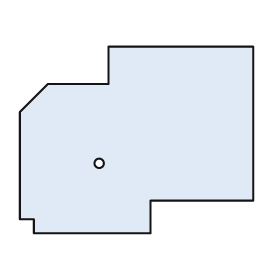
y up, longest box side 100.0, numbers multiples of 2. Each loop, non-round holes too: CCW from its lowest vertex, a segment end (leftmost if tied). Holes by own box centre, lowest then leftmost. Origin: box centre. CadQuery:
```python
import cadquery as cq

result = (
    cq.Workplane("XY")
    .moveTo(-44.0, -40.0)
    .lineTo(6.0, -40.0)
    .lineTo(6.0, -26.0)
    .lineTo(50.0, -26.0)
    .lineTo(50.0, 40.0)
    .lineTo(-12.0, 40.0)
    .lineTo(-12.0, 24.0)
    .lineTo(-38.0, 24.0)
    .lineTo(-50.0, 12.0)
    .lineTo(-50.0, -34.0)
    .lineTo(-44.0, -34.0)
    .close()
    .moveTo(-16.0, -10.0)
    .circle(2.0)
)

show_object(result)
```